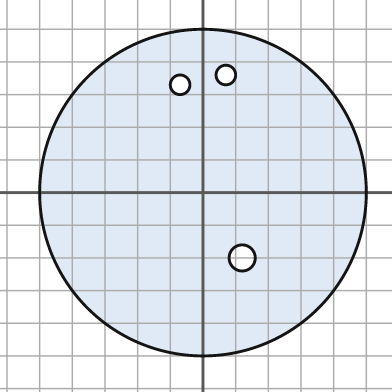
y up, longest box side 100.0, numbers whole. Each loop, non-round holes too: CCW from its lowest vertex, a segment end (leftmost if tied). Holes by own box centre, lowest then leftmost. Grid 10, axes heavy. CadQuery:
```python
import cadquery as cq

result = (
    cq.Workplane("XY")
    .moveTo(0.0, 0.0)
    .circle(50.0)
    .moveTo(12.0, -20.0)
    .circle(4.0)
    .moveTo(-7.0, 33.0)
    .circle(3.0)
    .moveTo(7.0, 36.0)
    .circle(3.0)
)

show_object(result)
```